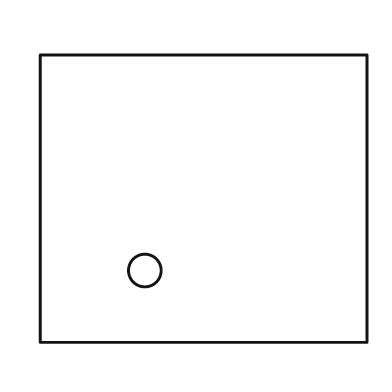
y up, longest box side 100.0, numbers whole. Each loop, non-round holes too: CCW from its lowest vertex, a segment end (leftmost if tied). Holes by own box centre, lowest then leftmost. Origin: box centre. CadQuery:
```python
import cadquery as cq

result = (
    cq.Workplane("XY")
    .moveTo(-50.0, -44.0)
    .lineTo(50.0, -44.0)
    .lineTo(50.0, 44.0)
    .lineTo(-50.0, 44.0)
    .close()
    .moveTo(-18.0, -22.0)
    .circle(5.0)
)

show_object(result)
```